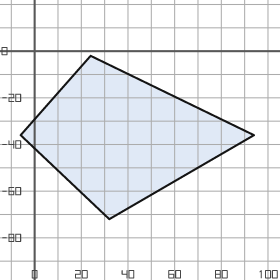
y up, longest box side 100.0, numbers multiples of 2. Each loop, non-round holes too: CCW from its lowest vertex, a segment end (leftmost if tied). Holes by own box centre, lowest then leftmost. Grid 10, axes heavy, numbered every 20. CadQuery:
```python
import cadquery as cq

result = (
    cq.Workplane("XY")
    .moveTo(32.0, -72.0)
    .lineTo(94.0, -36.0)
    .lineTo(24.0, -2.0)
    .lineTo(-6.0, -36.0)
    .close()
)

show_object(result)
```